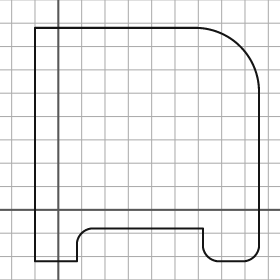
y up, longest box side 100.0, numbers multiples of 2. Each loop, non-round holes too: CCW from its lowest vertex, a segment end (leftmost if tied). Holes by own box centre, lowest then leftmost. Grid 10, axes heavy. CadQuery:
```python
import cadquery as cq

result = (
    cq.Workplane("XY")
    .moveTo(-10.0, -22.0)
    .lineTo(8.0, -22.0)
    .lineTo(8.0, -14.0)
    .threePointArc((10.0, -10.0), (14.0, -8.0))
    .lineTo(62.0, -8.0)
    .lineTo(62.0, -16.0)
    .threePointArc((64.0, -20.0), (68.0, -22.0))
    .lineTo(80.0, -22.0)
    .threePointArc((84.0, -20.0), (86.0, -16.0))
    .lineTo(86.0, 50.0)
    .threePointArc((78.0, 70.0), (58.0, 78.0))
    .lineTo(-10.0, 78.0)
    .close()
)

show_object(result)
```